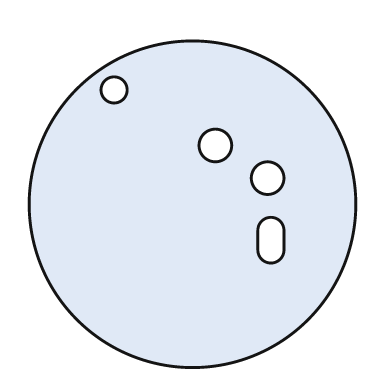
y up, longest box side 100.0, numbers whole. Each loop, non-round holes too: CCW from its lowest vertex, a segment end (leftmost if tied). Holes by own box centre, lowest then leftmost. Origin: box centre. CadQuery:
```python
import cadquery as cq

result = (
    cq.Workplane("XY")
    .moveTo(0.0, 0.0)
    .circle(50.0)
    .moveTo(20.0, -14.0)
    .threePointArc((24.0, -18.0), (28.0, -14.0))
    .lineTo(28.0, -8.0)
    .threePointArc((24.0, -4.0), (20.0, -8.0))
    .close()
    .moveTo(23.0, 8.0)
    .circle(5.0)
    .moveTo(7.0, 18.0)
    .circle(5.0)
    .moveTo(-24.0, 35.0)
    .circle(4.0)
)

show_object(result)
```